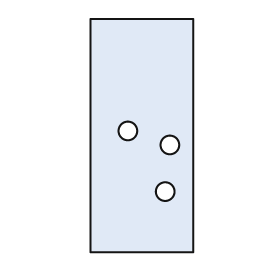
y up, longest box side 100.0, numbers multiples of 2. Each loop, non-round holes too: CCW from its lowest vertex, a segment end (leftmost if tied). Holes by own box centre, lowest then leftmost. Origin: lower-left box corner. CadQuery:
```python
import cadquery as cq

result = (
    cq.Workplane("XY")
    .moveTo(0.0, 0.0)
    .lineTo(44.0, 0.0)
    .lineTo(44.0, 100.0)
    .lineTo(0.0, 100.0)
    .close()
    .moveTo(32.0, 26.0)
    .circle(4.0)
    .moveTo(34.0, 46.0)
    .circle(4.0)
    .moveTo(16.0, 52.0)
    .circle(4.0)
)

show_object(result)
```